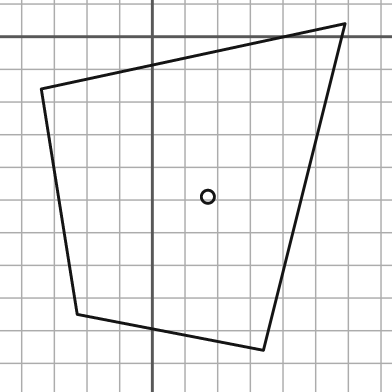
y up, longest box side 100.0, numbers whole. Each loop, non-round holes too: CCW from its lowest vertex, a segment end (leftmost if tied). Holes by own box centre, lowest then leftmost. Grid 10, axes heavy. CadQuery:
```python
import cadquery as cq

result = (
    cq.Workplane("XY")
    .moveTo(34.0, -96.0)
    .lineTo(59.0, 4.0)
    .lineTo(-34.0, -16.0)
    .lineTo(-23.0, -85.0)
    .close()
    .moveTo(17.0, -49.0)
    .circle(2.0)
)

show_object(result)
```